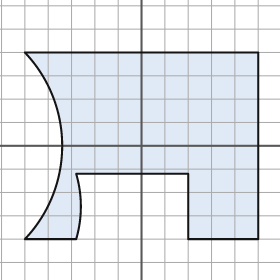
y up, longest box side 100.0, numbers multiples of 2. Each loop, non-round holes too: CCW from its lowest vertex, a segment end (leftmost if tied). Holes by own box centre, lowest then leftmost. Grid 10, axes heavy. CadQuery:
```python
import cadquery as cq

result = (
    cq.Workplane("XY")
    .moveTo(-50.0, -40.0)
    .lineTo(-28.0, -40.0)
    .threePointArc((-26.0, -26.0), (-28.0, -12.0))
    .lineTo(20.0, -12.0)
    .lineTo(20.0, -40.0)
    .lineTo(50.0, -40.0)
    .lineTo(50.0, 40.0)
    .lineTo(-50.0, 40.0)
    .threePointArc((-34.0, 0.0), (-50.0, -40.0))
    .close()
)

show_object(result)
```